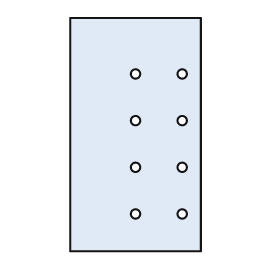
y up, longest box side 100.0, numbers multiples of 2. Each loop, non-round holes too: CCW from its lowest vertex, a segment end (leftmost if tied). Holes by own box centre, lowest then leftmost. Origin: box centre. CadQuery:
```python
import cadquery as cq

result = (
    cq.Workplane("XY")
    .moveTo(-28.0, -50.0)
    .lineTo(28.0, -50.0)
    .lineTo(28.0, 50.0)
    .lineTo(-28.0, 50.0)
    .close()
    .moveTo(0.0, -34.0)
    .circle(2.0)
    .moveTo(20.0, -34.0)
    .circle(2.0)
    .moveTo(0.0, -14.0)
    .circle(2.0)
    .moveTo(20.0, -14.0)
    .circle(2.0)
    .moveTo(0.0, 6.0)
    .circle(2.0)
    .moveTo(20.0, 6.0)
    .circle(2.0)
    .moveTo(0.0, 26.0)
    .circle(2.0)
    .moveTo(20.0, 26.0)
    .circle(2.0)
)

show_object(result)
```